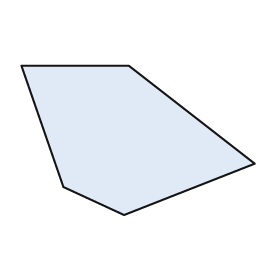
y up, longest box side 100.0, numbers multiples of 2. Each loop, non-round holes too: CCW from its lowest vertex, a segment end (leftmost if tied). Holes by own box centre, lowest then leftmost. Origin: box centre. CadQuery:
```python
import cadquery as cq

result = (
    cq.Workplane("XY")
    .moveTo(-6.0, -32.0)
    .lineTo(50.0, -10.0)
    .lineTo(-4.0, 32.0)
    .lineTo(-50.0, 32.0)
    .lineTo(-32.0, -20.0)
    .close()
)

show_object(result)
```